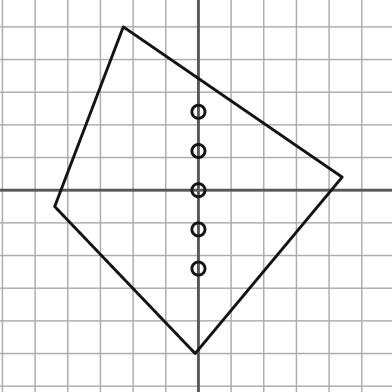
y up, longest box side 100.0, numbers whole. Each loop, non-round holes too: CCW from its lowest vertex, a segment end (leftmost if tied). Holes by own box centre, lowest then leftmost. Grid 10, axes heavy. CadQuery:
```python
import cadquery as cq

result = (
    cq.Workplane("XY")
    .moveTo(-1.0, -50.0)
    .lineTo(44.0, 4.0)
    .lineTo(-23.0, 50.0)
    .lineTo(-44.0, -5.0)
    .close()
    .moveTo(0.0, -24.0)
    .circle(2.0)
    .moveTo(0.0, -12.0)
    .circle(2.0)
    .moveTo(0.0, 0.0)
    .circle(2.0)
    .moveTo(0.0, 12.0)
    .circle(2.0)
    .moveTo(0.0, 24.0)
    .circle(2.0)
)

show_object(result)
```